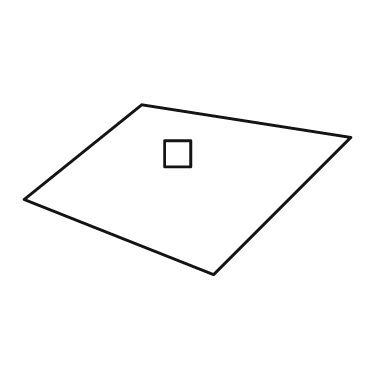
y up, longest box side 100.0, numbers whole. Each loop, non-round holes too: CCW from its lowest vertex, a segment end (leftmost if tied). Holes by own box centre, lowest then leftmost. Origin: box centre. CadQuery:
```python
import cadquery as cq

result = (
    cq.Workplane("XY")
    .moveTo(8.0, -26.0)
    .lineTo(50.0, 16.0)
    .lineTo(-14.0, 26.0)
    .lineTo(-50.0, -3.0)
    .close()
    .moveTo(-7.0, 7.0)
    .lineTo(1.0, 7.0)
    .lineTo(1.0, 15.0)
    .lineTo(-7.0, 15.0)
    .close()
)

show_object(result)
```